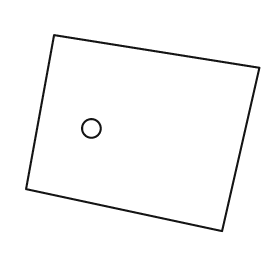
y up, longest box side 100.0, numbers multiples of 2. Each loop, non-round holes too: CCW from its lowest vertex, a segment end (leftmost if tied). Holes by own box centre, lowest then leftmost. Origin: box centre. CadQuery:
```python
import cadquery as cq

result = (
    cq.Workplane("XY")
    .moveTo(34.0, -42.0)
    .lineTo(50.0, 28.0)
    .lineTo(-38.0, 42.0)
    .lineTo(-50.0, -24.0)
    .close()
    .moveTo(-22.0, 2.0)
    .circle(4.0)
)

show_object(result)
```